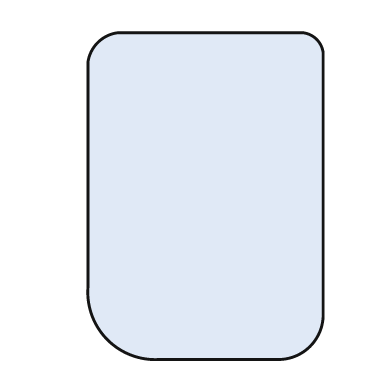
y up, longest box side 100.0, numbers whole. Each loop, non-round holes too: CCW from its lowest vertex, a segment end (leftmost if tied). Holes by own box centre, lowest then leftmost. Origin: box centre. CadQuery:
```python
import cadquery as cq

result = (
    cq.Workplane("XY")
    .moveTo(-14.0, -50.0)
    .lineTo(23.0, -50.0)
    .threePointArc((32.0, -46.0), (36.0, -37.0))
    .lineTo(36.0, 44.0)
    .threePointArc((34.0, 48.0), (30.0, 50.0))
    .lineTo(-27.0, 50.0)
    .threePointArc((-33.0, 47.0), (-36.0, 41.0))
    .lineTo(-36.0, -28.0)
    .threePointArc((-30.0, -44.0), (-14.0, -50.0))
    .close()
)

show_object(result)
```